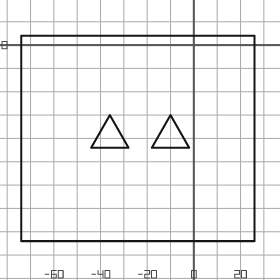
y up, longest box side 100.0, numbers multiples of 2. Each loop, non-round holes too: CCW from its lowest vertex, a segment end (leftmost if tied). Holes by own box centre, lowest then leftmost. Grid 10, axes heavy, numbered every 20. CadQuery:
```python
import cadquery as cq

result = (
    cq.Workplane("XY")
    .moveTo(-74.0, -84.0)
    .lineTo(26.0, -84.0)
    .lineTo(26.0, 4.0)
    .lineTo(-74.0, 4.0)
    .close()
    .moveTo(-44.0, -44.0)
    .lineTo(-28.0, -44.0)
    .lineTo(-36.0, -30.0)
    .close()
    .moveTo(-18.0, -44.0)
    .lineTo(-2.0, -44.0)
    .lineTo(-10.0, -30.0)
    .close()
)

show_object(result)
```